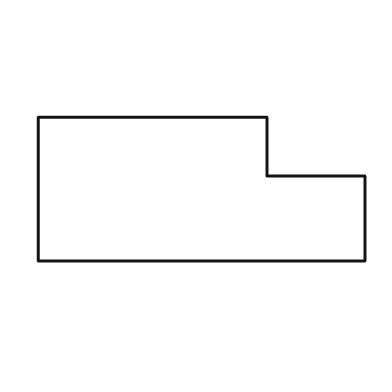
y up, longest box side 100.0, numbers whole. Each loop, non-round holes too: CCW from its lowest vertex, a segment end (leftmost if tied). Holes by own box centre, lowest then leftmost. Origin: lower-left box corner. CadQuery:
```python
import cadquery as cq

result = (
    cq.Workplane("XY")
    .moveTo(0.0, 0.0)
    .lineTo(100.0, 0.0)
    .lineTo(100.0, 26.0)
    .lineTo(70.0, 26.0)
    .lineTo(70.0, 44.0)
    .lineTo(0.0, 44.0)
    .close()
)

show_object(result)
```